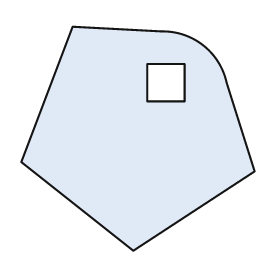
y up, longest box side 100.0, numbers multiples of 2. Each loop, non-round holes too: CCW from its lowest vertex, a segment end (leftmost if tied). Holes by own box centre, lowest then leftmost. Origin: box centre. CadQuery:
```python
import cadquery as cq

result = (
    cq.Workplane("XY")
    .moveTo(-2.0, -48.0)
    .lineTo(50.0, -14.0)
    .lineTo(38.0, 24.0)
    .threePointArc((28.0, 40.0), (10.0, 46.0))
    .lineTo(-28.0, 48.0)
    .lineTo(-50.0, -10.0)
    .close()
    .moveTo(4.0, 16.0)
    .lineTo(20.0, 16.0)
    .lineTo(20.0, 32.0)
    .lineTo(4.0, 32.0)
    .close()
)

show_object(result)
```